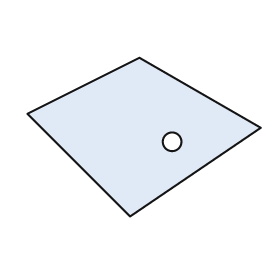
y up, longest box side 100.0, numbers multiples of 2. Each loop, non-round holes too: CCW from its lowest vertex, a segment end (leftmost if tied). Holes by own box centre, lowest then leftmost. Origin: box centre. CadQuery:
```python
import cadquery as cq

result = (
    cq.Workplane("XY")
    .moveTo(-6.0, -34.0)
    .lineTo(50.0, 4.0)
    .lineTo(-2.0, 34.0)
    .lineTo(-50.0, 10.0)
    .close()
    .moveTo(12.0, -2.0)
    .circle(4.0)
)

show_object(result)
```